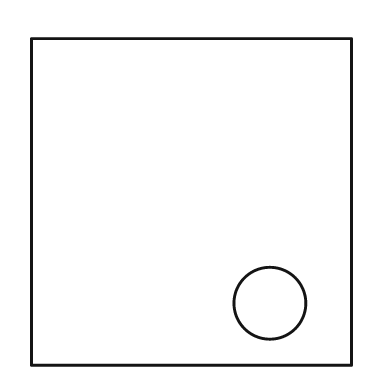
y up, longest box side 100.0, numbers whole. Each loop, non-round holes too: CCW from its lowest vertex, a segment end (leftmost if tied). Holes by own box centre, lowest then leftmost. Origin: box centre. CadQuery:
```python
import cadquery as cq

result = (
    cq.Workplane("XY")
    .moveTo(-49.0, -50.0)
    .lineTo(49.0, -50.0)
    .lineTo(49.0, 50.0)
    .lineTo(-49.0, 50.0)
    .close()
    .moveTo(24.0, -31.0)
    .circle(11.0)
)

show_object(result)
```